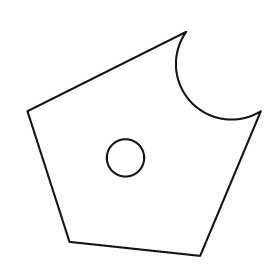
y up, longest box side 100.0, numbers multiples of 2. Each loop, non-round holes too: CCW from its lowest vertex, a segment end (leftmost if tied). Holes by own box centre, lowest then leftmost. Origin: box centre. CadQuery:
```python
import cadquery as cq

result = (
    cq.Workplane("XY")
    .moveTo(24.0, -48.0)
    .lineTo(50.0, 14.0)
    .threePointArc((20.0, 18.0), (18.0, 48.0))
    .lineTo(-50.0, 14.0)
    .lineTo(-32.0, -42.0)
    .close()
    .moveTo(-8.0, -6.0)
    .circle(8.0)
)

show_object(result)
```